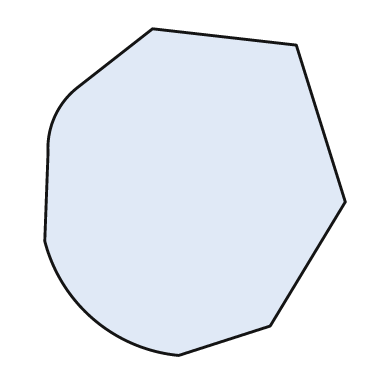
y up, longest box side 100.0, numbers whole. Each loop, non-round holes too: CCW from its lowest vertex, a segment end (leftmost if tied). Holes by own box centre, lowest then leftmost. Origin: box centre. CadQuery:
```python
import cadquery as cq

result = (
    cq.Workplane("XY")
    .moveTo(-5.0, -50.0)
    .lineTo(23.0, -41.0)
    .lineTo(46.0, -3.0)
    .lineTo(31.0, 45.0)
    .lineTo(-13.0, 50.0)
    .lineTo(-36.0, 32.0)
    .threePointArc((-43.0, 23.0), (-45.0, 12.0))
    .lineTo(-46.0, -15.0)
    .threePointArc((-31.0, -39.0), (-5.0, -50.0))
    .close()
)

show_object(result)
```